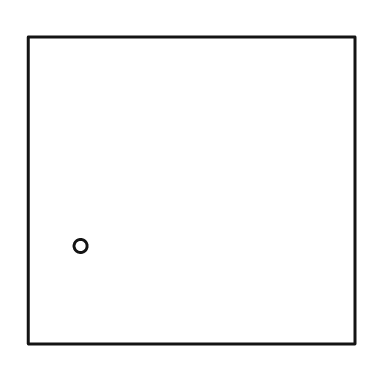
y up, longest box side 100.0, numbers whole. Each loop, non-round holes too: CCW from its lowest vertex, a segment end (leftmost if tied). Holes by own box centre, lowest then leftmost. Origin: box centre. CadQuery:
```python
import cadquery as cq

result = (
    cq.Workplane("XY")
    .moveTo(-50.0, -47.0)
    .lineTo(50.0, -47.0)
    .lineTo(50.0, 47.0)
    .lineTo(-50.0, 47.0)
    .close()
    .moveTo(-34.0, -17.0)
    .circle(2.0)
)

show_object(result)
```